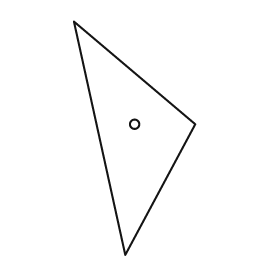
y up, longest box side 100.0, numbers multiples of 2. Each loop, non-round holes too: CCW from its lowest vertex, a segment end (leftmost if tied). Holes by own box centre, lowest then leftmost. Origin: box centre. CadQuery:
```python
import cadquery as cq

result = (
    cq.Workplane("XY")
    .moveTo(-4.0, -50.0)
    .lineTo(26.0, 6.0)
    .lineTo(-26.0, 50.0)
    .close()
    .moveTo(0.0, 6.0)
    .circle(2.0)
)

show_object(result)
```